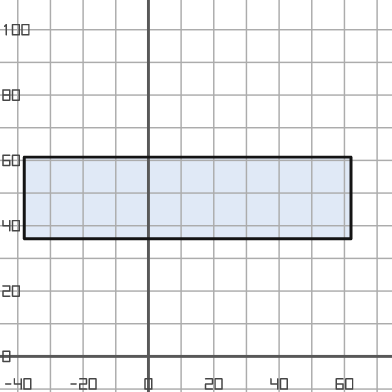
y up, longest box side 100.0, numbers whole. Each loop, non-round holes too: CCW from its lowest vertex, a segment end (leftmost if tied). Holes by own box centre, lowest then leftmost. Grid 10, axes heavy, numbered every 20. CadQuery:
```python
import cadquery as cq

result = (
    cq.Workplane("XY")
    .moveTo(-38.0, 36.0)
    .lineTo(62.0, 36.0)
    .lineTo(62.0, 61.0)
    .lineTo(-38.0, 61.0)
    .close()
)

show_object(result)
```